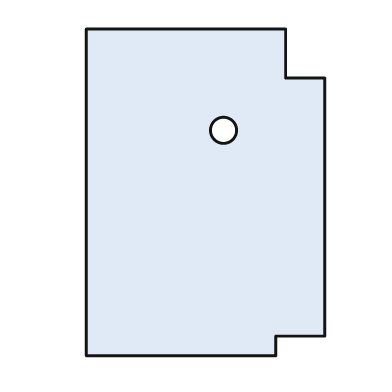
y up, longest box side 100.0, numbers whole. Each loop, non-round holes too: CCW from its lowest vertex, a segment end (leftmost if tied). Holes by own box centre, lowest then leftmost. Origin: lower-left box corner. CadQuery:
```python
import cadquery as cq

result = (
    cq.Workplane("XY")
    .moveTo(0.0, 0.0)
    .lineTo(58.0, 0.0)
    .lineTo(58.0, 6.0)
    .lineTo(73.0, 6.0)
    .lineTo(73.0, 85.0)
    .lineTo(61.0, 85.0)
    .lineTo(61.0, 100.0)
    .lineTo(0.0, 100.0)
    .close()
    .moveTo(42.0, 69.0)
    .circle(4.0)
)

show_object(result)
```